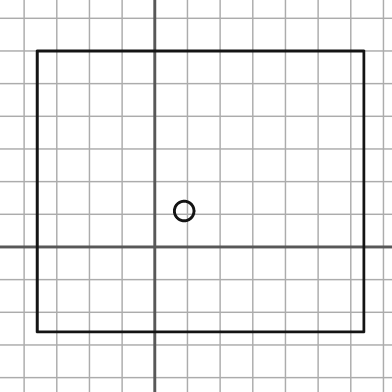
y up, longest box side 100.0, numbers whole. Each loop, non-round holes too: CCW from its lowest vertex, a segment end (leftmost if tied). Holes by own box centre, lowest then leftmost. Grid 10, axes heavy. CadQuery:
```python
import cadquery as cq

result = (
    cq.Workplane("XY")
    .moveTo(-36.0, -26.0)
    .lineTo(64.0, -26.0)
    .lineTo(64.0, 60.0)
    .lineTo(-36.0, 60.0)
    .close()
    .moveTo(9.0, 11.0)
    .circle(3.0)
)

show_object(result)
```